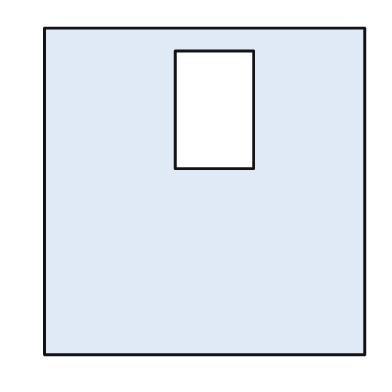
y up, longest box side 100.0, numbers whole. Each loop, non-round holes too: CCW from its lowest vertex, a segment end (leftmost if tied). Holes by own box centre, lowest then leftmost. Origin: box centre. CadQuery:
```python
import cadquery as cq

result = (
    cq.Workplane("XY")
    .moveTo(-49.0, -50.0)
    .lineTo(49.0, -50.0)
    .lineTo(49.0, 50.0)
    .lineTo(-49.0, 50.0)
    .close()
    .moveTo(-9.0, 7.0)
    .lineTo(15.0, 7.0)
    .lineTo(15.0, 43.0)
    .lineTo(-9.0, 43.0)
    .close()
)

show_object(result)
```